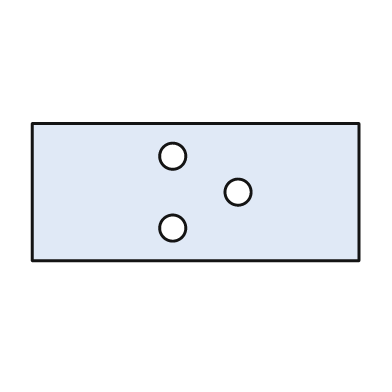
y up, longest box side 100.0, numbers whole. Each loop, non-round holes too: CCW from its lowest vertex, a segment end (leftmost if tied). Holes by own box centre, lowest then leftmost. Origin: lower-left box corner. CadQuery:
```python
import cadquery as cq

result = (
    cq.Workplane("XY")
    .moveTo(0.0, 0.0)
    .lineTo(100.0, 0.0)
    .lineTo(100.0, 42.0)
    .lineTo(0.0, 42.0)
    .close()
    .moveTo(43.0, 10.0)
    .circle(4.0)
    .moveTo(63.0, 21.0)
    .circle(4.0)
    .moveTo(43.0, 32.0)
    .circle(4.0)
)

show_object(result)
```